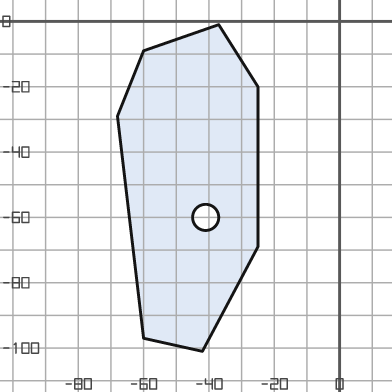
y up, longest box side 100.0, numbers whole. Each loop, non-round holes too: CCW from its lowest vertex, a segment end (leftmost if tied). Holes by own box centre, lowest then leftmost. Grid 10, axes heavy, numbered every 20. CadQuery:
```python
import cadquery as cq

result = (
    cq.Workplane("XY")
    .moveTo(-42.0, -101.0)
    .lineTo(-25.0, -69.0)
    .lineTo(-25.0, -20.0)
    .lineTo(-37.0, -1.0)
    .lineTo(-60.0, -9.0)
    .lineTo(-68.0, -29.0)
    .lineTo(-60.0, -97.0)
    .close()
    .moveTo(-41.0, -60.0)
    .circle(4.0)
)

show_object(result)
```